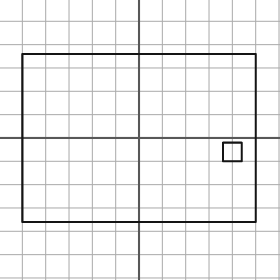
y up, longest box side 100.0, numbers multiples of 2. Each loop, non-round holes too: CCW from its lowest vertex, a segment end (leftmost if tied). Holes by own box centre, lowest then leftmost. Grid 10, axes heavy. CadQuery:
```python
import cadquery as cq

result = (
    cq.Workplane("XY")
    .moveTo(-50.0, -36.0)
    .lineTo(50.0, -36.0)
    .lineTo(50.0, 36.0)
    .lineTo(-50.0, 36.0)
    .close()
    .moveTo(36.0, -10.0)
    .lineTo(44.0, -10.0)
    .lineTo(44.0, -2.0)
    .lineTo(36.0, -2.0)
    .close()
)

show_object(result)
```